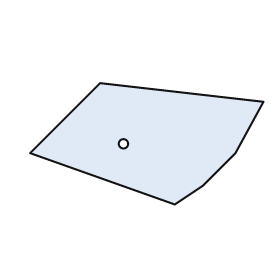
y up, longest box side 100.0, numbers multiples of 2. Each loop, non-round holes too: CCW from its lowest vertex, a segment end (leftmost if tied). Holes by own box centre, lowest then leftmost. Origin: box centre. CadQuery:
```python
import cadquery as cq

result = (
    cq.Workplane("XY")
    .moveTo(12.0, -26.0)
    .lineTo(24.0, -18.0)
    .lineTo(38.0, -4.0)
    .lineTo(50.0, 18.0)
    .lineTo(-20.0, 26.0)
    .lineTo(-50.0, -4.0)
    .close()
    .moveTo(-10.0, 0.0)
    .circle(2.0)
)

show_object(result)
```